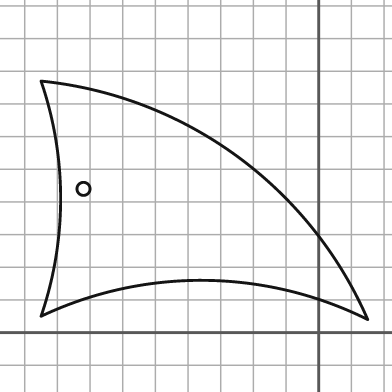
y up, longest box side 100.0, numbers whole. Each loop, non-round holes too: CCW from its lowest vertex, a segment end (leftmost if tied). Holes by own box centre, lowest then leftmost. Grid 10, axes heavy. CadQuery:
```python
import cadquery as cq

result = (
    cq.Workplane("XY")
    .moveTo(15.0, 4.0)
    .threePointArc((-25.0, 54.0), (-85.0, 77.0))
    .threePointArc((-79.0, 41.0), (-85.0, 5.0))
    .threePointArc((-35.0, 16.0), (15.0, 4.0))
    .close()
    .moveTo(-72.0, 44.0)
    .circle(2.0)
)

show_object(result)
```